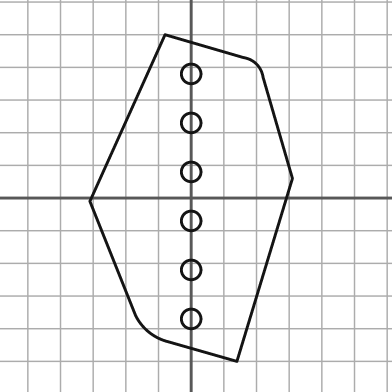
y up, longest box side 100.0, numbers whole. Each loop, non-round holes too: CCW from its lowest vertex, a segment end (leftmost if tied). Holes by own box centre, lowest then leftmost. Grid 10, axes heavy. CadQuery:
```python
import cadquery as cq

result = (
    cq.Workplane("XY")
    .moveTo(14.0, -50.0)
    .lineTo(31.0, 6.0)
    .lineTo(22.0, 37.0)
    .threePointArc((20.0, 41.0), (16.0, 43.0))
    .lineTo(-8.0, 50.0)
    .lineTo(-31.0, -1.0)
    .lineTo(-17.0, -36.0)
    .threePointArc((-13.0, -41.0), (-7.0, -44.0))
    .close()
    .moveTo(0.0, -37.0)
    .circle(3.0)
    .moveTo(0.0, -22.0)
    .circle(3.0)
    .moveTo(0.0, -7.0)
    .circle(3.0)
    .moveTo(0.0, 8.0)
    .circle(3.0)
    .moveTo(0.0, 23.0)
    .circle(3.0)
    .moveTo(0.0, 38.0)
    .circle(3.0)
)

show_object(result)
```